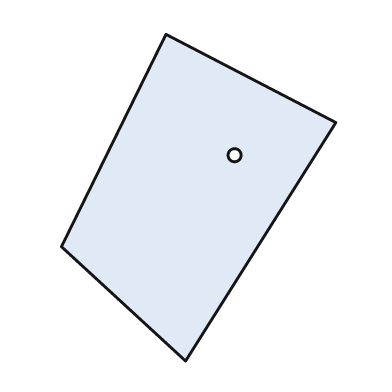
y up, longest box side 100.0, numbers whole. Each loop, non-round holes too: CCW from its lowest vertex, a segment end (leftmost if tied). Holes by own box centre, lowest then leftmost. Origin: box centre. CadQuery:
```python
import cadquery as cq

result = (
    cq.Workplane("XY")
    .moveTo(-4.0, -50.0)
    .lineTo(42.0, 23.0)
    .lineTo(-10.0, 50.0)
    .lineTo(-42.0, -15.0)
    .close()
    .moveTo(11.0, 13.0)
    .circle(2.0)
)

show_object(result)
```